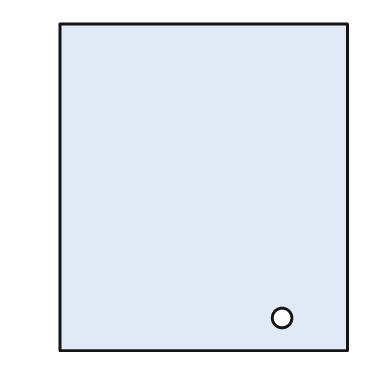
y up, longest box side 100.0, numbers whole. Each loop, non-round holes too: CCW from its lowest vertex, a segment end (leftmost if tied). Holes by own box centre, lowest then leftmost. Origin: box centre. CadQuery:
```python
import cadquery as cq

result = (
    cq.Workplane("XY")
    .moveTo(-44.0, -50.0)
    .lineTo(44.0, -50.0)
    .lineTo(44.0, 50.0)
    .lineTo(-44.0, 50.0)
    .close()
    .moveTo(24.0, -40.0)
    .circle(3.0)
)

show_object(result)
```